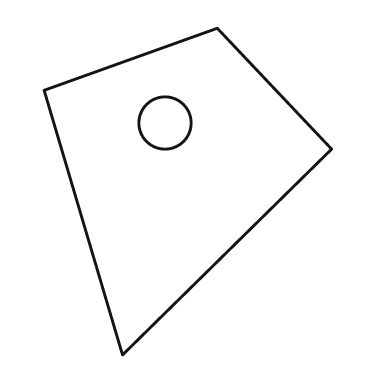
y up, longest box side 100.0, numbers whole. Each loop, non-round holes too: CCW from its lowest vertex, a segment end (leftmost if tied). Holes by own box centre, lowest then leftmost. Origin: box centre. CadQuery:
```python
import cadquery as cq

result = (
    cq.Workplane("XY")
    .moveTo(-20.0, -50.0)
    .lineTo(44.0, 13.0)
    .lineTo(9.0, 50.0)
    .lineTo(-44.0, 31.0)
    .close()
    .moveTo(-7.0, 21.0)
    .circle(8.0)
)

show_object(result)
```